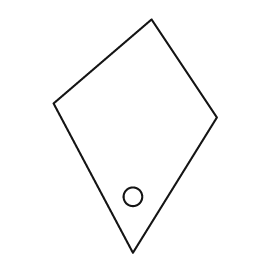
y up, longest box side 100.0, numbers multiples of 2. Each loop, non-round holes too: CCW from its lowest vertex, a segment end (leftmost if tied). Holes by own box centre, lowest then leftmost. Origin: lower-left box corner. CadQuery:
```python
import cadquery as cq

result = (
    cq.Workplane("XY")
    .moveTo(34.0, 0.0)
    .lineTo(70.0, 58.0)
    .lineTo(42.0, 100.0)
    .lineTo(0.0, 64.0)
    .close()
    .moveTo(34.0, 24.0)
    .circle(4.0)
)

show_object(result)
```